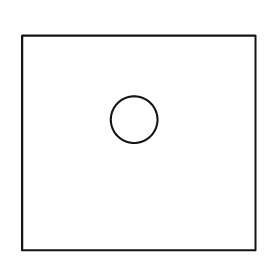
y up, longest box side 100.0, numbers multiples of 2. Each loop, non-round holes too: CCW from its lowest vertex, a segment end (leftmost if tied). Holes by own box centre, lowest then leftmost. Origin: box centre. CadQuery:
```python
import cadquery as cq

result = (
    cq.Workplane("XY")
    .moveTo(-50.0, -46.0)
    .lineTo(50.0, -46.0)
    .lineTo(50.0, 46.0)
    .lineTo(-50.0, 46.0)
    .close()
    .moveTo(-2.0, 10.0)
    .circle(10.0)
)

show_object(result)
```